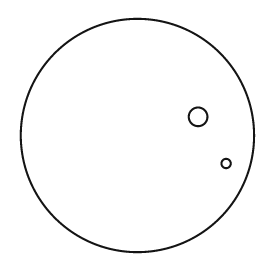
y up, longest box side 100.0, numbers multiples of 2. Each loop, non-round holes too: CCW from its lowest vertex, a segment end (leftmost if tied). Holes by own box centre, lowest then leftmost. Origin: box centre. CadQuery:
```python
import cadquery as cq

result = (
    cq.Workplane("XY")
    .moveTo(0.0, 0.0)
    .circle(50.0)
    .moveTo(38.0, -12.0)
    .circle(2.0)
    .moveTo(26.0, 8.0)
    .circle(4.0)
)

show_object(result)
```